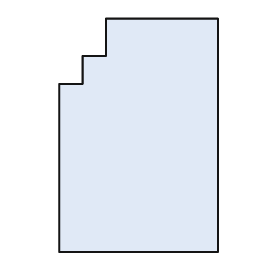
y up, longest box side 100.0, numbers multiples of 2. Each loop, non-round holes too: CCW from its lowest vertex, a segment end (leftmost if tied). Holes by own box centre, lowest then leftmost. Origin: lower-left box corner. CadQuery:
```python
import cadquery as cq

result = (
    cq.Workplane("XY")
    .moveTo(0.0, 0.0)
    .lineTo(68.0, 0.0)
    .lineTo(68.0, 100.0)
    .lineTo(20.0, 100.0)
    .lineTo(20.0, 84.0)
    .lineTo(10.0, 84.0)
    .lineTo(10.0, 72.0)
    .lineTo(0.0, 72.0)
    .close()
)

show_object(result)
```